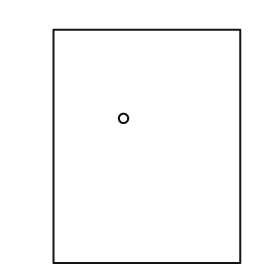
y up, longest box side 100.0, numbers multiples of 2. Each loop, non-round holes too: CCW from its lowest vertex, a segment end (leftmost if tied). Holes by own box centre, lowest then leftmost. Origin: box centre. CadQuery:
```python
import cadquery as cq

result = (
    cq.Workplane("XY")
    .moveTo(-40.0, -50.0)
    .lineTo(40.0, -50.0)
    .lineTo(40.0, 50.0)
    .lineTo(-40.0, 50.0)
    .close()
    .moveTo(-10.0, 12.0)
    .circle(2.0)
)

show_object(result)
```